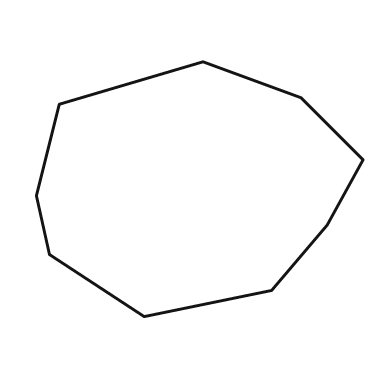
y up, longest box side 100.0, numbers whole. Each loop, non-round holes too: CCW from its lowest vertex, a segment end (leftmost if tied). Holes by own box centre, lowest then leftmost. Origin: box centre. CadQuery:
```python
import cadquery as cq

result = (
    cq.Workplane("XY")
    .moveTo(-17.0, -39.0)
    .lineTo(22.0, -31.0)
    .lineTo(39.0, -11.0)
    .lineTo(50.0, 9.0)
    .lineTo(31.0, 28.0)
    .lineTo(1.0, 39.0)
    .lineTo(-43.0, 26.0)
    .lineTo(-50.0, -2.0)
    .lineTo(-46.0, -20.0)
    .close()
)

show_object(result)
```